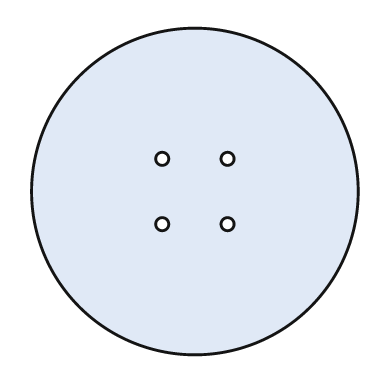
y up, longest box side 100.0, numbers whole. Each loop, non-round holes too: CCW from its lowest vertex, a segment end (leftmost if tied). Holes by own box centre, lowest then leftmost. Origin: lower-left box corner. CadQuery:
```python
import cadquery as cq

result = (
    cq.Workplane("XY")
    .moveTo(50.0, 50.0)
    .circle(50.0)
    .moveTo(40.0, 40.0)
    .circle(2.0)
    .moveTo(60.0, 40.0)
    .circle(2.0)
    .moveTo(40.0, 60.0)
    .circle(2.0)
    .moveTo(60.0, 60.0)
    .circle(2.0)
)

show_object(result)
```